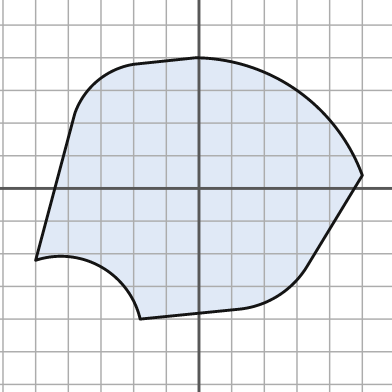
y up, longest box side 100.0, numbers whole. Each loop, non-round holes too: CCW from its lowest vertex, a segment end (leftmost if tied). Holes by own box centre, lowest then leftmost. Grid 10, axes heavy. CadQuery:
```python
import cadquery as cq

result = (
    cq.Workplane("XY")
    .moveTo(-18.0, -40.0)
    .lineTo(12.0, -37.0)
    .threePointArc((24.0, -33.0), (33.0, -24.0))
    .lineTo(50.0, 4.0)
    .threePointArc((30.0, 30.0), (-1.0, 40.0))
    .lineTo(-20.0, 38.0)
    .threePointArc((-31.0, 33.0), (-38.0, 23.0))
    .lineTo(-50.0, -22.0)
    .threePointArc((-30.0, -24.0), (-18.0, -40.0))
    .close()
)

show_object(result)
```